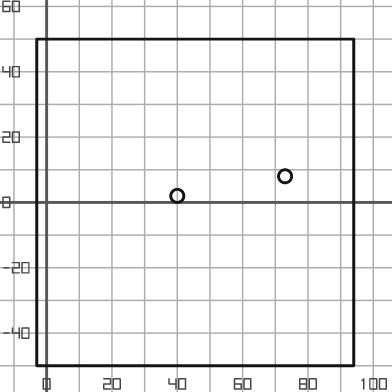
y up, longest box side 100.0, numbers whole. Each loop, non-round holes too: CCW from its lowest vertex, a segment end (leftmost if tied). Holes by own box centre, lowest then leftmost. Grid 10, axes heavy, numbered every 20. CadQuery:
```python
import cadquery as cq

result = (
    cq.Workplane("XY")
    .moveTo(-3.0, -50.0)
    .lineTo(94.0, -50.0)
    .lineTo(94.0, 50.0)
    .lineTo(-3.0, 50.0)
    .close()
    .moveTo(40.0, 2.0)
    .circle(2.0)
    .moveTo(73.0, 8.0)
    .circle(2.0)
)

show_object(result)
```